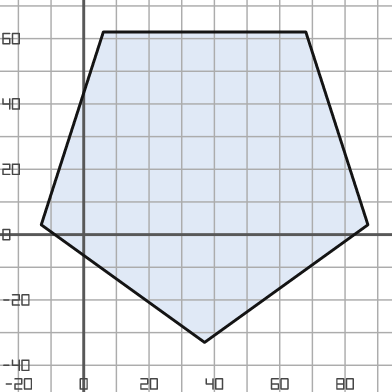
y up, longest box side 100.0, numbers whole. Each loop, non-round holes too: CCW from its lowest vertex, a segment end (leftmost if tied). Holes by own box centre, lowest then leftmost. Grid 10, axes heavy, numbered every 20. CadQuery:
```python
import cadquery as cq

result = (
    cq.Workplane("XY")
    .moveTo(37.0, -33.0)
    .lineTo(87.0, 3.0)
    .lineTo(68.0, 62.0)
    .lineTo(6.0, 62.0)
    .lineTo(-13.0, 3.0)
    .close()
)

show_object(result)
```